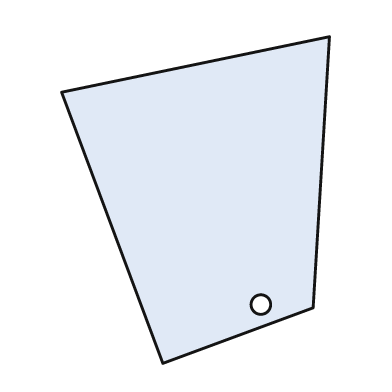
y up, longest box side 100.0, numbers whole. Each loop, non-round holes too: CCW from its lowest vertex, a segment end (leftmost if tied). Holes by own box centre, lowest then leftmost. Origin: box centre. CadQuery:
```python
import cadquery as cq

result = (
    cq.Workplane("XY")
    .moveTo(-10.0, -50.0)
    .lineTo(36.0, -33.0)
    .lineTo(41.0, 50.0)
    .lineTo(-41.0, 33.0)
    .close()
    .moveTo(20.0, -32.0)
    .circle(3.0)
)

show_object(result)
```